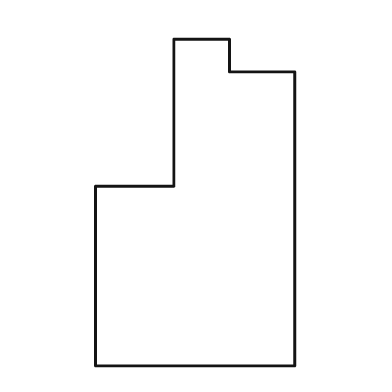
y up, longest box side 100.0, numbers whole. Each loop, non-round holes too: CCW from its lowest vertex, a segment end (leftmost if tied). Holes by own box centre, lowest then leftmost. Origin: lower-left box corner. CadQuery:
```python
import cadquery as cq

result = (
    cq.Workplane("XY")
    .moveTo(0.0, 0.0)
    .lineTo(61.0, 0.0)
    .lineTo(61.0, 90.0)
    .lineTo(41.0, 90.0)
    .lineTo(41.0, 100.0)
    .lineTo(24.0, 100.0)
    .lineTo(24.0, 55.0)
    .lineTo(0.0, 55.0)
    .close()
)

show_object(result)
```